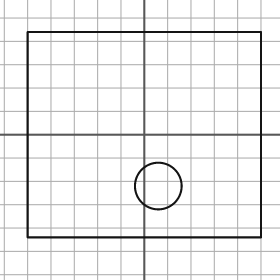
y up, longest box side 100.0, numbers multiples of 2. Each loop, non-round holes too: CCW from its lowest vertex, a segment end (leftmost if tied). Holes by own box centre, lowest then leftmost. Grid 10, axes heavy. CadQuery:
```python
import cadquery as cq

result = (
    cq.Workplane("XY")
    .moveTo(-50.0, -44.0)
    .lineTo(50.0, -44.0)
    .lineTo(50.0, 44.0)
    .lineTo(-50.0, 44.0)
    .close()
    .moveTo(6.0, -22.0)
    .circle(10.0)
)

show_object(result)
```